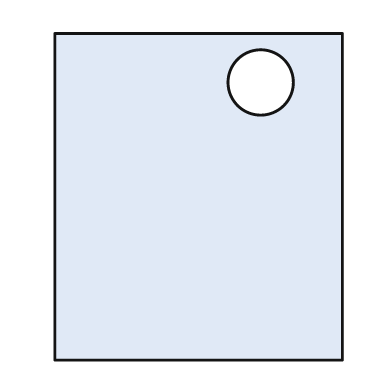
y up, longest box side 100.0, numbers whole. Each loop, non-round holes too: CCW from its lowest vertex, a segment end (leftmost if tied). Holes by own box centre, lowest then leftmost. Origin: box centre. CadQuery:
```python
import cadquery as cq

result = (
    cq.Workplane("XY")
    .moveTo(-44.0, -50.0)
    .lineTo(44.0, -50.0)
    .lineTo(44.0, 50.0)
    .lineTo(-44.0, 50.0)
    .close()
    .moveTo(19.0, 35.0)
    .circle(10.0)
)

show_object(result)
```